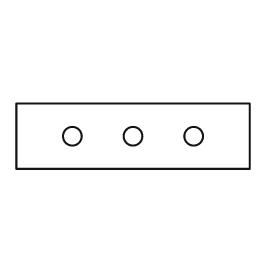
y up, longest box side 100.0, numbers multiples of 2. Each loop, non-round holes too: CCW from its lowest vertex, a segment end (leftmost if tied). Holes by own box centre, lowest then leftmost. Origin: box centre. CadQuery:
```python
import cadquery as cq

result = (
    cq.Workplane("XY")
    .moveTo(-50.0, -14.0)
    .lineTo(50.0, -14.0)
    .lineTo(50.0, 14.0)
    .lineTo(-50.0, 14.0)
    .close()
    .moveTo(-26.0, 0.0)
    .circle(4.0)
    .moveTo(0.0, 0.0)
    .circle(4.0)
    .moveTo(26.0, 0.0)
    .circle(4.0)
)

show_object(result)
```